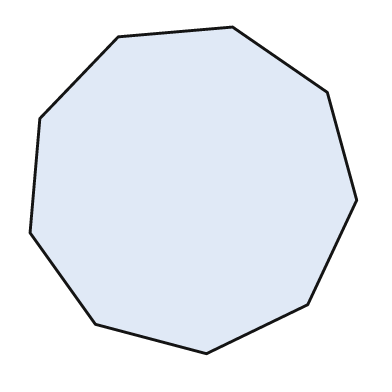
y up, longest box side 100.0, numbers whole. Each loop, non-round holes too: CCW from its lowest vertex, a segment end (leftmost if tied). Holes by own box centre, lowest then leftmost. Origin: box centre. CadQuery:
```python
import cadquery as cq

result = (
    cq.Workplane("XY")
    .moveTo(4.0, -50.0)
    .lineTo(35.0, -35.0)
    .lineTo(50.0, -3.0)
    .lineTo(41.0, 30.0)
    .lineTo(12.0, 50.0)
    .lineTo(-23.0, 47.0)
    .lineTo(-47.0, 22.0)
    .lineTo(-50.0, -13.0)
    .lineTo(-30.0, -41.0)
    .close()
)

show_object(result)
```